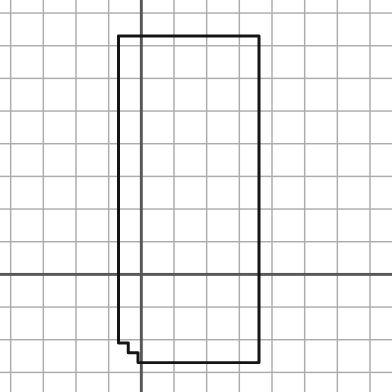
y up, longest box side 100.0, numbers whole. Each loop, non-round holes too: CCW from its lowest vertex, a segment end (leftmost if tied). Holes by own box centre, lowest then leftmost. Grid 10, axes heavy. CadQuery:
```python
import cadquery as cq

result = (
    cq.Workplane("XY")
    .moveTo(-1.0, -27.0)
    .lineTo(36.0, -27.0)
    .lineTo(36.0, 73.0)
    .lineTo(-7.0, 73.0)
    .lineTo(-7.0, -21.0)
    .lineTo(-4.0, -21.0)
    .lineTo(-4.0, -24.0)
    .lineTo(-1.0, -24.0)
    .close()
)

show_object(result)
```